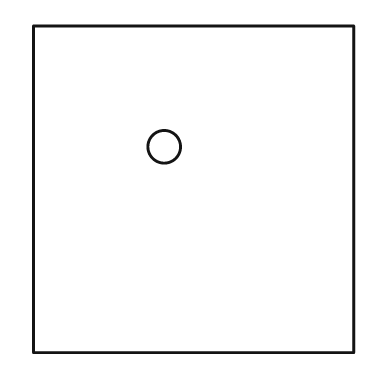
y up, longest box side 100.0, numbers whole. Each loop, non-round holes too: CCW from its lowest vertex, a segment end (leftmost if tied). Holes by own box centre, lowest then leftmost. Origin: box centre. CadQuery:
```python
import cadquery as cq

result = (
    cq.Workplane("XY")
    .moveTo(-49.0, -50.0)
    .lineTo(49.0, -50.0)
    .lineTo(49.0, 50.0)
    .lineTo(-49.0, 50.0)
    .close()
    .moveTo(-9.0, 13.0)
    .circle(5.0)
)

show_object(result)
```